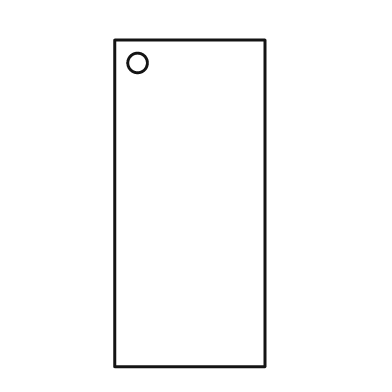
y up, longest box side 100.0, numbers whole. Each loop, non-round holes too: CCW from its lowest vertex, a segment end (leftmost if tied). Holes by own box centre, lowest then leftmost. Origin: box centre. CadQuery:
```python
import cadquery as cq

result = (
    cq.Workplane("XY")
    .moveTo(-23.0, -50.0)
    .lineTo(23.0, -50.0)
    .lineTo(23.0, 50.0)
    .lineTo(-23.0, 50.0)
    .close()
    .moveTo(-16.0, 43.0)
    .circle(3.0)
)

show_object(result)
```